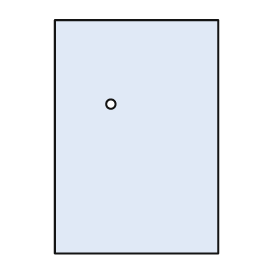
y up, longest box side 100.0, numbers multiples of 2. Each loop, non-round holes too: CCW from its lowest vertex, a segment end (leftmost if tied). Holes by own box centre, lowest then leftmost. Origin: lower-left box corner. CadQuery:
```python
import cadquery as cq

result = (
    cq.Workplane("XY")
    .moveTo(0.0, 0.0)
    .lineTo(70.0, 0.0)
    .lineTo(70.0, 100.0)
    .lineTo(0.0, 100.0)
    .close()
    .moveTo(24.0, 64.0)
    .circle(2.0)
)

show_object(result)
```